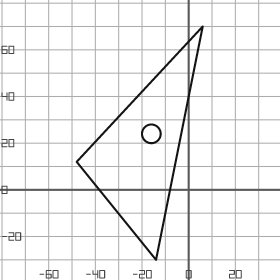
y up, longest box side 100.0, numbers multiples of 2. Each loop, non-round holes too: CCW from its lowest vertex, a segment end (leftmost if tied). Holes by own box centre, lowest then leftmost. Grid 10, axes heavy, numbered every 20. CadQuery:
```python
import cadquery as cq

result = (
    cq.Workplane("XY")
    .moveTo(-14.0, -30.0)
    .lineTo(6.0, 70.0)
    .lineTo(-48.0, 12.0)
    .close()
    .moveTo(-16.0, 24.0)
    .circle(4.0)
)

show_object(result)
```